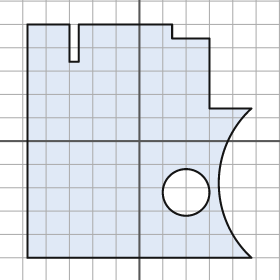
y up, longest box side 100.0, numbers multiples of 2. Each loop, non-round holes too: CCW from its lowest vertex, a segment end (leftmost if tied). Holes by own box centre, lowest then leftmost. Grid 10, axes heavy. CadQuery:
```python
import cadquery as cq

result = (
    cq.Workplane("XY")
    .moveTo(-48.0, -50.0)
    .lineTo(48.0, -50.0)
    .threePointArc((34.0, -18.0), (48.0, 14.0))
    .lineTo(30.0, 14.0)
    .lineTo(30.0, 44.0)
    .lineTo(14.0, 44.0)
    .lineTo(14.0, 50.0)
    .lineTo(-26.0, 50.0)
    .lineTo(-26.0, 34.0)
    .lineTo(-30.0, 34.0)
    .lineTo(-30.0, 50.0)
    .lineTo(-48.0, 50.0)
    .close()
    .moveTo(20.0, -22.0)
    .circle(10.0)
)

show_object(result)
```